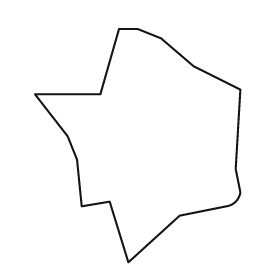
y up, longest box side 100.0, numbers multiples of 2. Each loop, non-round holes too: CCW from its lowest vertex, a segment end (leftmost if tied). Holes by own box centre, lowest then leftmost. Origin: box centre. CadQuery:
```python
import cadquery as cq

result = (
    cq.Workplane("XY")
    .moveTo(-4.0, -50.0)
    .lineTo(18.0, -30.0)
    .lineTo(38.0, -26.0)
    .threePointArc((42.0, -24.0), (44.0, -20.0))
    .lineTo(42.0, -10.0)
    .lineTo(44.0, 24.0)
    .lineTo(24.0, 34.0)
    .lineTo(10.0, 46.0)
    .lineTo(0.0, 50.0)
    .lineTo(-8.0, 50.0)
    .lineTo(-16.0, 22.0)
    .lineTo(-44.0, 22.0)
    .lineTo(-30.0, 4.0)
    .lineTo(-26.0, -6.0)
    .lineTo(-24.0, -26.0)
    .lineTo(-12.0, -24.0)
    .close()
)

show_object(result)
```